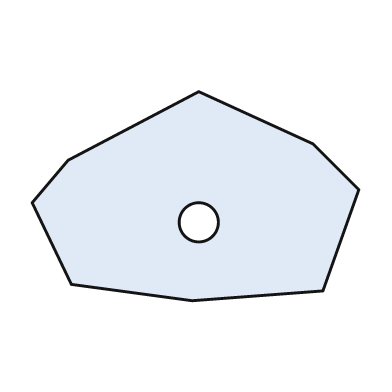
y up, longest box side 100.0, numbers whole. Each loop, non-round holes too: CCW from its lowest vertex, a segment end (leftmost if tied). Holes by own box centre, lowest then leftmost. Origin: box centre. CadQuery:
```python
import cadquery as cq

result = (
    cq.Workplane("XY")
    .moveTo(-1.0, -32.0)
    .lineTo(39.0, -29.0)
    .lineTo(50.0, 2.0)
    .lineTo(36.0, 16.0)
    .lineTo(1.0, 32.0)
    .lineTo(-39.0, 11.0)
    .lineTo(-50.0, -2.0)
    .lineTo(-38.0, -27.0)
    .close()
    .moveTo(1.0, -8.0)
    .circle(6.0)
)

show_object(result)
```